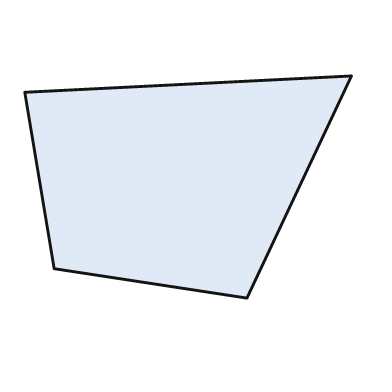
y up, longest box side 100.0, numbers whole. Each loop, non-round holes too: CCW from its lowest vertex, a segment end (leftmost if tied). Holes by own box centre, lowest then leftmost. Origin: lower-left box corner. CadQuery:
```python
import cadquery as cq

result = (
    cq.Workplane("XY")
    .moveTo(68.0, 0.0)
    .lineTo(100.0, 68.0)
    .lineTo(0.0, 63.0)
    .lineTo(9.0, 9.0)
    .close()
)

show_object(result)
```